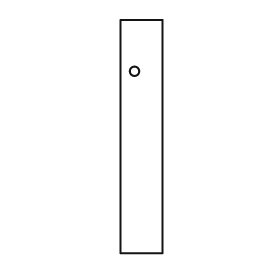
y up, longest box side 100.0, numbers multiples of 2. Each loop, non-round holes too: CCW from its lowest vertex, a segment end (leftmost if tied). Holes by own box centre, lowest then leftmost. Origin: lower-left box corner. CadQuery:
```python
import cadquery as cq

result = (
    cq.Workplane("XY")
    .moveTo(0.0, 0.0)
    .lineTo(18.0, 0.0)
    .lineTo(18.0, 100.0)
    .lineTo(0.0, 100.0)
    .close()
    .moveTo(6.0, 78.0)
    .circle(2.0)
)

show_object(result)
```